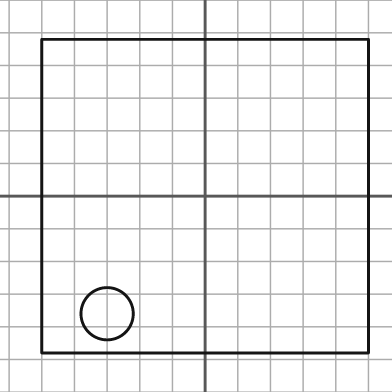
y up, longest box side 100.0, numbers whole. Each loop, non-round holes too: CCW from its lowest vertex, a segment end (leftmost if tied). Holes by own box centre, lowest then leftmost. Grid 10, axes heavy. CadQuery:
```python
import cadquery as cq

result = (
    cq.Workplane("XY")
    .moveTo(-50.0, -48.0)
    .lineTo(50.0, -48.0)
    .lineTo(50.0, 48.0)
    .lineTo(-50.0, 48.0)
    .close()
    .moveTo(-30.0, -36.0)
    .circle(8.0)
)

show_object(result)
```